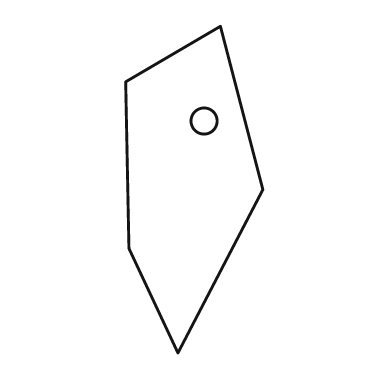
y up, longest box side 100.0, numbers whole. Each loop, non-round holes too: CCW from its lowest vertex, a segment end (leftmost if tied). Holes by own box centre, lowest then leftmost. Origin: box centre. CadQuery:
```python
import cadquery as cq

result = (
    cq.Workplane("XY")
    .moveTo(-5.0, -50.0)
    .lineTo(21.0, 0.0)
    .lineTo(8.0, 50.0)
    .lineTo(-21.0, 33.0)
    .lineTo(-20.0, -18.0)
    .close()
    .moveTo(3.0, 21.0)
    .circle(4.0)
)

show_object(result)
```